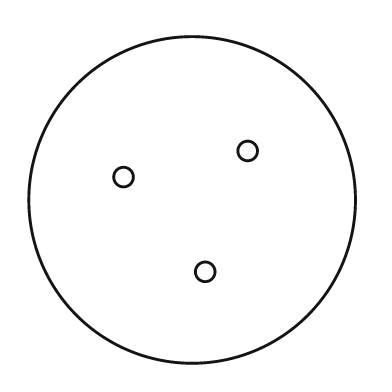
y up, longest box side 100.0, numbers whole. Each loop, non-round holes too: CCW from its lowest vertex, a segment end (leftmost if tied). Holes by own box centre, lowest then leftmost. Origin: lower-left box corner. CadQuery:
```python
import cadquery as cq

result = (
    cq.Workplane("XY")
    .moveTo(50.0, 50.0)
    .circle(50.0)
    .moveTo(54.0, 28.0)
    .circle(3.0)
    .moveTo(29.0, 57.0)
    .circle(3.0)
    .moveTo(67.0, 65.0)
    .circle(3.0)
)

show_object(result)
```